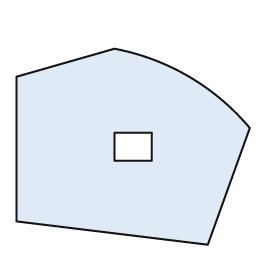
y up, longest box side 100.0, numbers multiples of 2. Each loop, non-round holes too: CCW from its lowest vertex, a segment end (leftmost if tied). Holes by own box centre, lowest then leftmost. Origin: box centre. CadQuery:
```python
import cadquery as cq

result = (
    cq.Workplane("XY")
    .moveTo(32.0, -42.0)
    .lineTo(50.0, 8.0)
    .threePointArc((24.0, 30.0), (-8.0, 42.0))
    .lineTo(-50.0, 30.0)
    .lineTo(-50.0, -32.0)
    .close()
    .moveTo(-8.0, -6.0)
    .lineTo(8.0, -6.0)
    .lineTo(8.0, 6.0)
    .lineTo(-8.0, 6.0)
    .close()
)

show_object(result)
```